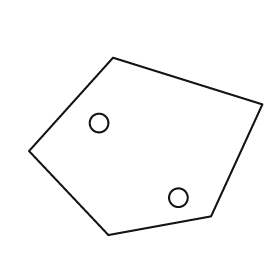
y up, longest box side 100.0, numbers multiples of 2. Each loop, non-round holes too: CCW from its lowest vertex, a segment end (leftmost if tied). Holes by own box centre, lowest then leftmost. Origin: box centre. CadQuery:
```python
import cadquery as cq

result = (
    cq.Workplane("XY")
    .moveTo(-16.0, -38.0)
    .lineTo(28.0, -30.0)
    .lineTo(50.0, 18.0)
    .lineTo(-14.0, 38.0)
    .lineTo(-50.0, -2.0)
    .close()
    .moveTo(14.0, -22.0)
    .circle(4.0)
    .moveTo(-20.0, 10.0)
    .circle(4.0)
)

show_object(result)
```